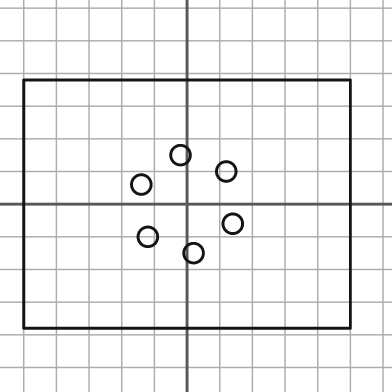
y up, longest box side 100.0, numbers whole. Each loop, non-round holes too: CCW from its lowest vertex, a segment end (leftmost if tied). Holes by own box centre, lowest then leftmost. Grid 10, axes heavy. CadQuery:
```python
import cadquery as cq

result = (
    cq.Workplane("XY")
    .moveTo(-50.0, -38.0)
    .lineTo(50.0, -38.0)
    .lineTo(50.0, 38.0)
    .lineTo(-50.0, 38.0)
    .close()
    .moveTo(2.0, -15.0)
    .circle(3.0)
    .moveTo(-12.0, -10.0)
    .circle(3.0)
    .moveTo(14.0, -6.0)
    .circle(3.0)
    .moveTo(-14.0, 6.0)
    .circle(3.0)
    .moveTo(12.0, 10.0)
    .circle(3.0)
    .moveTo(-2.0, 15.0)
    .circle(3.0)
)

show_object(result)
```